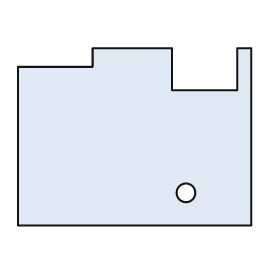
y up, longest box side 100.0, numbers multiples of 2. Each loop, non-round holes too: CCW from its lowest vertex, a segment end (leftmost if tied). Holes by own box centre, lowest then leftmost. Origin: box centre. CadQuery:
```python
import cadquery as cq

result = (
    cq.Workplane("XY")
    .moveTo(-50.0, -38.0)
    .lineTo(50.0, -38.0)
    .lineTo(50.0, 38.0)
    .lineTo(44.0, 38.0)
    .lineTo(44.0, 20.0)
    .lineTo(16.0, 20.0)
    .lineTo(16.0, 38.0)
    .lineTo(-18.0, 38.0)
    .lineTo(-18.0, 30.0)
    .lineTo(-50.0, 30.0)
    .close()
    .moveTo(22.0, -24.0)
    .circle(4.0)
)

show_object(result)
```